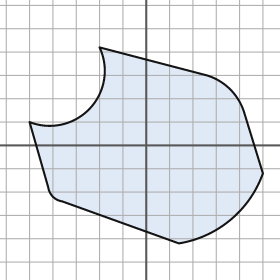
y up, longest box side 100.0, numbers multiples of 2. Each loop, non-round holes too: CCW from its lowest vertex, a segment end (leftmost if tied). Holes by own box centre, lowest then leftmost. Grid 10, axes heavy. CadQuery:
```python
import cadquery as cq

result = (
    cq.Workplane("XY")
    .moveTo(14.0, -42.0)
    .threePointArc((36.0, -32.0), (50.0, -12.0))
    .lineTo(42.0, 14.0)
    .threePointArc((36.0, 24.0), (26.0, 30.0))
    .lineTo(-20.0, 42.0)
    .threePointArc((-24.0, 16.0), (-50.0, 10.0))
    .lineTo(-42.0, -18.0)
    .threePointArc((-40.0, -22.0), (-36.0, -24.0))
    .close()
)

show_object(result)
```